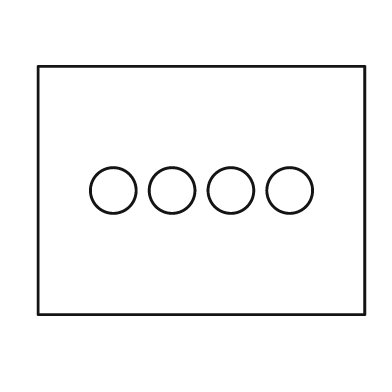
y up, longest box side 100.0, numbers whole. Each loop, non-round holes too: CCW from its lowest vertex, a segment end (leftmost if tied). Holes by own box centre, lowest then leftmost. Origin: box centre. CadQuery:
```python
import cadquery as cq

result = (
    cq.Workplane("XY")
    .moveTo(-50.0, -38.0)
    .lineTo(50.0, -38.0)
    .lineTo(50.0, 38.0)
    .lineTo(-50.0, 38.0)
    .close()
    .moveTo(-27.0, 0.0)
    .circle(7.0)
    .moveTo(-9.0, 0.0)
    .circle(7.0)
    .moveTo(9.0, 0.0)
    .circle(7.0)
    .moveTo(27.0, 0.0)
    .circle(7.0)
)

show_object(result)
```